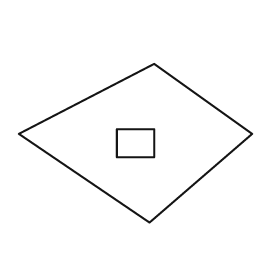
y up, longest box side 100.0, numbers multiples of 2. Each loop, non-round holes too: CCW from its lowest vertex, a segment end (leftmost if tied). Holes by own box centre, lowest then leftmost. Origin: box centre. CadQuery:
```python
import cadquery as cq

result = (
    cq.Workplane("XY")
    .moveTo(6.0, -34.0)
    .lineTo(50.0, 4.0)
    .lineTo(8.0, 34.0)
    .lineTo(-50.0, 4.0)
    .close()
    .moveTo(-8.0, -6.0)
    .lineTo(8.0, -6.0)
    .lineTo(8.0, 6.0)
    .lineTo(-8.0, 6.0)
    .close()
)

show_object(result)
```